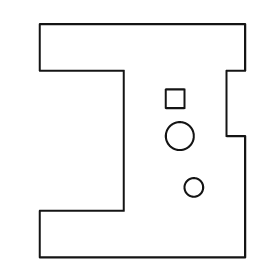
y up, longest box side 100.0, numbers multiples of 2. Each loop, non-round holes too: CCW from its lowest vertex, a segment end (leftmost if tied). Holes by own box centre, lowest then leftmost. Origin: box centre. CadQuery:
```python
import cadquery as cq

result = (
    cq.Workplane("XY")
    .moveTo(-44.0, -50.0)
    .lineTo(44.0, -50.0)
    .lineTo(44.0, 2.0)
    .lineTo(36.0, 2.0)
    .lineTo(36.0, 30.0)
    .lineTo(44.0, 30.0)
    .lineTo(44.0, 50.0)
    .lineTo(-44.0, 50.0)
    .lineTo(-44.0, 30.0)
    .lineTo(-8.0, 30.0)
    .lineTo(-8.0, -30.0)
    .lineTo(-44.0, -30.0)
    .close()
    .moveTo(22.0, -20.0)
    .circle(4.0)
    .moveTo(16.0, 2.0)
    .circle(6.0)
    .moveTo(10.0, 14.0)
    .lineTo(18.0, 14.0)
    .lineTo(18.0, 22.0)
    .lineTo(10.0, 22.0)
    .close()
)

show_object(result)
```